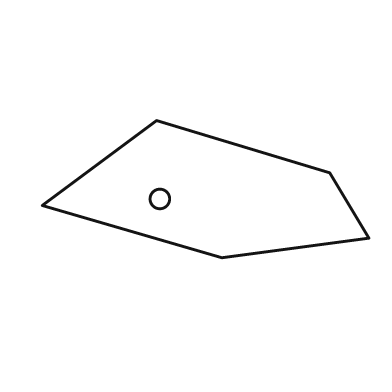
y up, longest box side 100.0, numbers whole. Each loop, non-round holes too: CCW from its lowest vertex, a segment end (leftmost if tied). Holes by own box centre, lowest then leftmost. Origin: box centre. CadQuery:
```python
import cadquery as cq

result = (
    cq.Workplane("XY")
    .moveTo(5.0, -21.0)
    .lineTo(50.0, -15.0)
    .lineTo(38.0, 5.0)
    .lineTo(-15.0, 21.0)
    .lineTo(-50.0, -5.0)
    .close()
    .moveTo(-14.0, -3.0)
    .circle(3.0)
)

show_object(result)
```